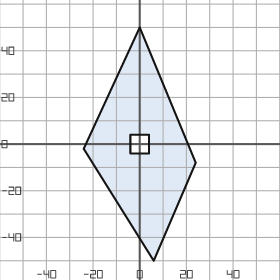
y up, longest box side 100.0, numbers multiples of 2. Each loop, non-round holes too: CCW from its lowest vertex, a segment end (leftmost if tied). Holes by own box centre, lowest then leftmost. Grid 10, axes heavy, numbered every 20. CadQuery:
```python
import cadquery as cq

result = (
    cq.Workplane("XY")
    .moveTo(6.0, -50.0)
    .lineTo(24.0, -8.0)
    .lineTo(0.0, 50.0)
    .lineTo(-24.0, -2.0)
    .close()
    .moveTo(-4.0, -4.0)
    .lineTo(4.0, -4.0)
    .lineTo(4.0, 4.0)
    .lineTo(-4.0, 4.0)
    .close()
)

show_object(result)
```